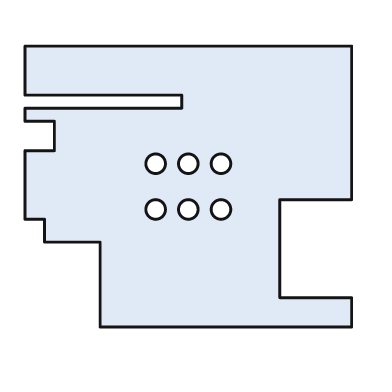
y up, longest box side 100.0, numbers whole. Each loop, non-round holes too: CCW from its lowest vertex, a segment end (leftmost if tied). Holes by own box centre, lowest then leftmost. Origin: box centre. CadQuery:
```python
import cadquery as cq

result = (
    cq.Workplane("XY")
    .moveTo(-27.0, -43.0)
    .lineTo(50.0, -43.0)
    .lineTo(50.0, -34.0)
    .lineTo(28.0, -34.0)
    .lineTo(28.0, -4.0)
    .lineTo(50.0, -4.0)
    .lineTo(50.0, 43.0)
    .lineTo(-50.0, 43.0)
    .lineTo(-50.0, 28.0)
    .lineTo(-2.0, 28.0)
    .lineTo(-2.0, 24.0)
    .lineTo(-50.0, 24.0)
    .lineTo(-50.0, 20.0)
    .lineTo(-41.0, 20.0)
    .lineTo(-41.0, 11.0)
    .lineTo(-50.0, 11.0)
    .lineTo(-50.0, -10.0)
    .lineTo(-44.0, -10.0)
    .lineTo(-44.0, -17.0)
    .lineTo(-27.0, -17.0)
    .close()
    .moveTo(-10.0, -7.0)
    .circle(3.0)
    .moveTo(0.0, -7.0)
    .circle(3.0)
    .moveTo(10.0, -7.0)
    .circle(3.0)
    .moveTo(-10.0, 7.0)
    .circle(3.0)
    .moveTo(0.0, 7.0)
    .circle(3.0)
    .moveTo(10.0, 7.0)
    .circle(3.0)
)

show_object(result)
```